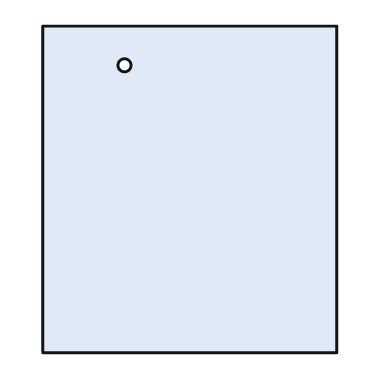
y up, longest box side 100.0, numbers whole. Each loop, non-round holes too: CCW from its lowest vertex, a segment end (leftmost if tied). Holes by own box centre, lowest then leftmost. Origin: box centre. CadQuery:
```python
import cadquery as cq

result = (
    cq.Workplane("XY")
    .moveTo(-45.0, -50.0)
    .lineTo(45.0, -50.0)
    .lineTo(45.0, 50.0)
    .lineTo(-45.0, 50.0)
    .close()
    .moveTo(-20.0, 38.0)
    .circle(2.0)
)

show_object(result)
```